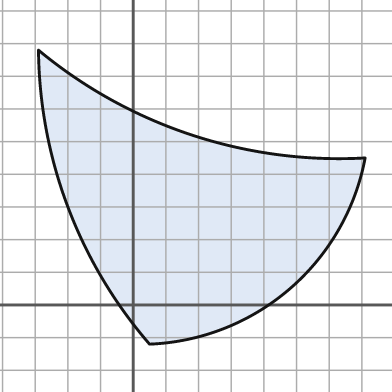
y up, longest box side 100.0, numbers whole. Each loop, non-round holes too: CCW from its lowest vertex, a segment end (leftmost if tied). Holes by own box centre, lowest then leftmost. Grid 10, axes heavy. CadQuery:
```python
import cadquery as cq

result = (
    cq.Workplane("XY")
    .moveTo(5.0, -12.0)
    .threePointArc((48.0, 5.0), (71.0, 45.0))
    .threePointArc((18.0, 52.0), (-29.0, 78.0))
    .threePointArc((-20.0, 30.0), (5.0, -12.0))
    .close()
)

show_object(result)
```